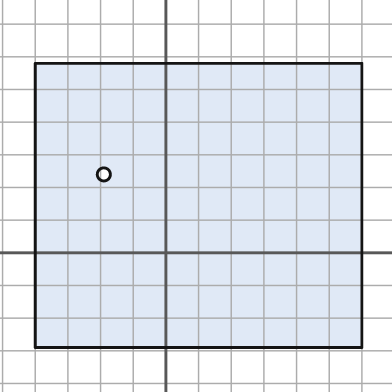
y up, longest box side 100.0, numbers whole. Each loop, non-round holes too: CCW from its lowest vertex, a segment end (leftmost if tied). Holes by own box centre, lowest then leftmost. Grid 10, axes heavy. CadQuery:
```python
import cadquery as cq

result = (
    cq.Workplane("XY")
    .moveTo(-40.0, -29.0)
    .lineTo(60.0, -29.0)
    .lineTo(60.0, 58.0)
    .lineTo(-40.0, 58.0)
    .close()
    .moveTo(-19.0, 24.0)
    .circle(2.0)
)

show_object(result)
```